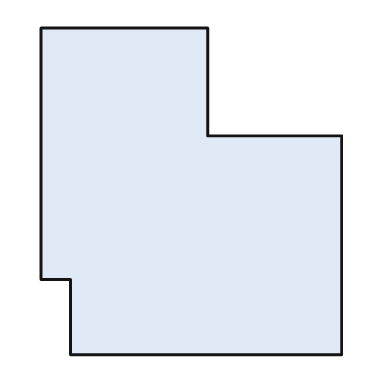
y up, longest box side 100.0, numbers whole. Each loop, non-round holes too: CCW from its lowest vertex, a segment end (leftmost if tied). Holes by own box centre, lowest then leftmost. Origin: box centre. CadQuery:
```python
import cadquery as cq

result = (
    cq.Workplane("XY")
    .moveTo(-37.0, -50.0)
    .lineTo(46.0, -50.0)
    .lineTo(46.0, 17.0)
    .lineTo(5.0, 17.0)
    .lineTo(5.0, 50.0)
    .lineTo(-46.0, 50.0)
    .lineTo(-46.0, -27.0)
    .lineTo(-37.0, -27.0)
    .close()
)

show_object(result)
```